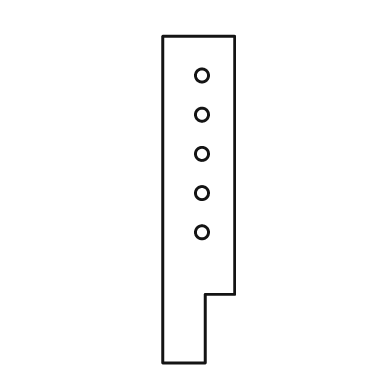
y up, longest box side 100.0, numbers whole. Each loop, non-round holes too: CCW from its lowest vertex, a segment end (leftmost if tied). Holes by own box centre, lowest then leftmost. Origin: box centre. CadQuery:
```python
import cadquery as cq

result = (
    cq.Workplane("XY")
    .moveTo(-11.0, -50.0)
    .lineTo(2.0, -50.0)
    .lineTo(2.0, -29.0)
    .lineTo(11.0, -29.0)
    .lineTo(11.0, 50.0)
    .lineTo(-11.0, 50.0)
    .close()
    .moveTo(1.0, -10.0)
    .circle(2.0)
    .moveTo(1.0, 2.0)
    .circle(2.0)
    .moveTo(1.0, 14.0)
    .circle(2.0)
    .moveTo(1.0, 26.0)
    .circle(2.0)
    .moveTo(1.0, 38.0)
    .circle(2.0)
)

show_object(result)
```